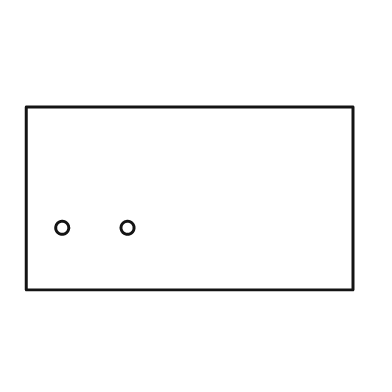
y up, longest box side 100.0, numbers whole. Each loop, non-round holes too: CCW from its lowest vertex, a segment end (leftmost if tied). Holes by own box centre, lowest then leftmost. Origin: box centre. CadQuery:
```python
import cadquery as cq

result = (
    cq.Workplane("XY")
    .moveTo(-50.0, -28.0)
    .lineTo(50.0, -28.0)
    .lineTo(50.0, 28.0)
    .lineTo(-50.0, 28.0)
    .close()
    .moveTo(-39.0, -9.0)
    .circle(2.0)
    .moveTo(-19.0, -9.0)
    .circle(2.0)
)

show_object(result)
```